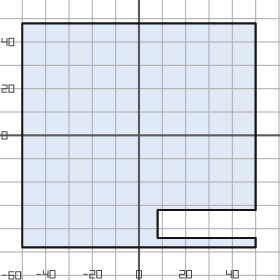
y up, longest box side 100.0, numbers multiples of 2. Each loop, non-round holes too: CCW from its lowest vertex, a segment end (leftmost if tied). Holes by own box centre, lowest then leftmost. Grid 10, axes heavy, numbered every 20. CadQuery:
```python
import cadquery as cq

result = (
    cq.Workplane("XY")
    .moveTo(-50.0, -48.0)
    .lineTo(50.0, -48.0)
    .lineTo(50.0, -44.0)
    .lineTo(8.0, -44.0)
    .lineTo(8.0, -32.0)
    .lineTo(50.0, -32.0)
    .lineTo(50.0, 48.0)
    .lineTo(-50.0, 48.0)
    .close()
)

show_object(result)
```